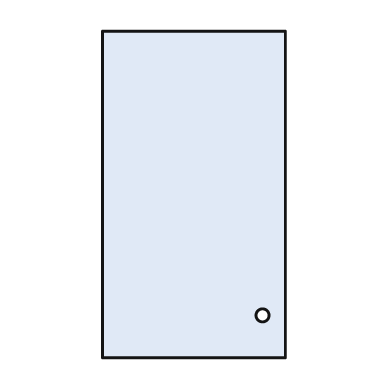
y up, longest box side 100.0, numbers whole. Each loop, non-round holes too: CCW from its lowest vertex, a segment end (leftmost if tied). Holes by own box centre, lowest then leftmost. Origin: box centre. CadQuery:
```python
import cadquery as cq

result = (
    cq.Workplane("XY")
    .moveTo(-28.0, -50.0)
    .lineTo(28.0, -50.0)
    .lineTo(28.0, 50.0)
    .lineTo(-28.0, 50.0)
    .close()
    .moveTo(21.0, -37.0)
    .circle(2.0)
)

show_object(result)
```